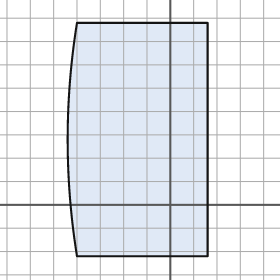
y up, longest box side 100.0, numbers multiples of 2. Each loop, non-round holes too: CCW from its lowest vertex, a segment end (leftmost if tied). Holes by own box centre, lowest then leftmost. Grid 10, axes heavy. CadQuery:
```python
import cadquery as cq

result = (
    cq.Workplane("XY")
    .moveTo(-40.0, -22.0)
    .lineTo(16.0, -22.0)
    .lineTo(16.0, 78.0)
    .lineTo(-40.0, 78.0)
    .threePointArc((-44.0, 28.0), (-40.0, -22.0))
    .close()
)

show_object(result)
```